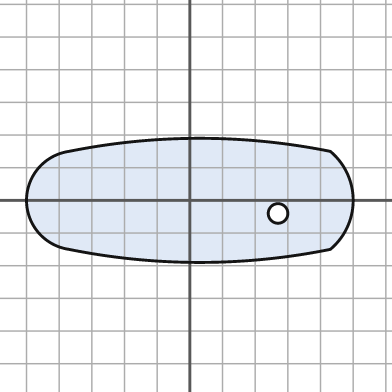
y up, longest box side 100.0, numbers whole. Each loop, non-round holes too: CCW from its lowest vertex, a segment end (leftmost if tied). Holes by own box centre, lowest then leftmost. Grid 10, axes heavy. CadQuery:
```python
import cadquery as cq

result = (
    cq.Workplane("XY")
    .moveTo(-37.0, -15.0)
    .threePointArc((3.0, -19.0), (43.0, -15.0))
    .threePointArc((50.0, 0.0), (43.0, 15.0))
    .threePointArc((3.0, 19.0), (-37.0, 15.0))
    .threePointArc((-50.0, 0.0), (-37.0, -15.0))
    .close()
    .moveTo(27.0, -4.0)
    .circle(3.0)
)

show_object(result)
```